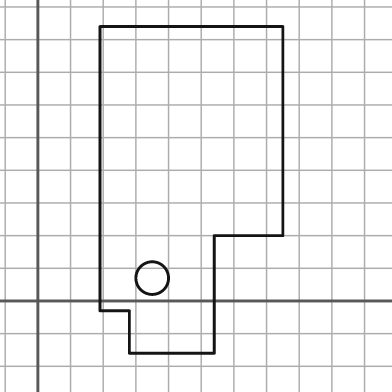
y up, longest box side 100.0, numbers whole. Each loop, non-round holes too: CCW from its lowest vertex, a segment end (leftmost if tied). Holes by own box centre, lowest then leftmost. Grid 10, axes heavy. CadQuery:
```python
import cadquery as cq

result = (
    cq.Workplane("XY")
    .moveTo(28.0, -16.0)
    .lineTo(54.0, -16.0)
    .lineTo(54.0, 20.0)
    .lineTo(75.0, 20.0)
    .lineTo(75.0, 84.0)
    .lineTo(19.0, 84.0)
    .lineTo(19.0, -3.0)
    .lineTo(28.0, -3.0)
    .close()
    .moveTo(35.0, 7.0)
    .circle(5.0)
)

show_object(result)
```